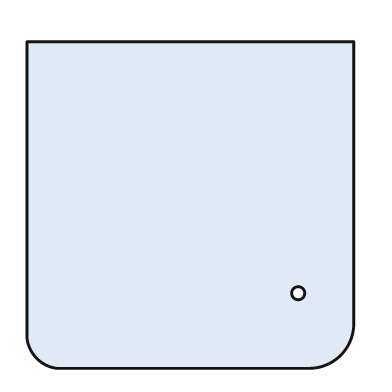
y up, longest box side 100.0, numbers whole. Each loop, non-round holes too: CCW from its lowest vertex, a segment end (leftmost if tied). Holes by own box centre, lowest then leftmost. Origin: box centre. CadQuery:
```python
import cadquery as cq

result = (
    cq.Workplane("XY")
    .moveTo(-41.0, -50.0)
    .lineTo(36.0, -50.0)
    .threePointArc((46.0, -46.0), (50.0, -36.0))
    .lineTo(50.0, 50.0)
    .lineTo(-50.0, 50.0)
    .lineTo(-50.0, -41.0)
    .threePointArc((-47.0, -47.0), (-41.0, -50.0))
    .close()
    .moveTo(33.0, -27.0)
    .circle(2.0)
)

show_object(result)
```